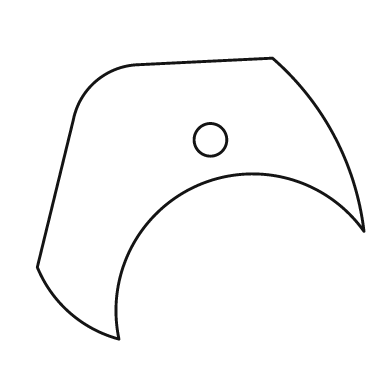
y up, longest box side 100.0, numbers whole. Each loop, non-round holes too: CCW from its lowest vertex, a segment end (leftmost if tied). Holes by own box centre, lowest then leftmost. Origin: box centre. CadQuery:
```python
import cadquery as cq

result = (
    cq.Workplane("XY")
    .moveTo(-25.0, -43.0)
    .threePointArc((-1.0, 4.0), (50.0, -10.0))
    .threePointArc((41.0, 19.0), (22.0, 43.0))
    .lineTo(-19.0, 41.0)
    .threePointArc((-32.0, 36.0), (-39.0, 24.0))
    .lineTo(-50.0, -21.0)
    .threePointArc((-40.0, -35.0), (-25.0, -43.0))
    .close()
    .moveTo(3.0, 18.0)
    .circle(5.0)
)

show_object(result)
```